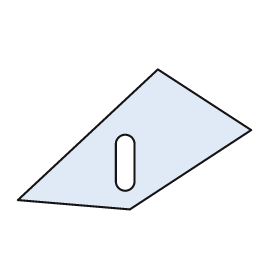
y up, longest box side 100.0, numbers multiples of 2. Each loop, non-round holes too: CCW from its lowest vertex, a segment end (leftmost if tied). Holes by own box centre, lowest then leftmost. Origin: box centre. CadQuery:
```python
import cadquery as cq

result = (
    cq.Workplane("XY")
    .moveTo(-2.0, -30.0)
    .lineTo(50.0, 4.0)
    .lineTo(10.0, 30.0)
    .lineTo(-50.0, -26.0)
    .close()
    .moveTo(-8.0, -18.0)
    .threePointArc((-4.0, -22.0), (0.0, -18.0))
    .lineTo(0.0, -2.0)
    .threePointArc((-4.0, 2.0), (-8.0, -2.0))
    .close()
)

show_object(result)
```